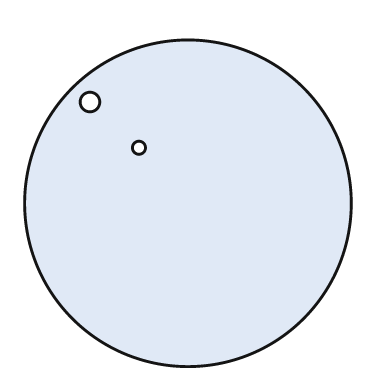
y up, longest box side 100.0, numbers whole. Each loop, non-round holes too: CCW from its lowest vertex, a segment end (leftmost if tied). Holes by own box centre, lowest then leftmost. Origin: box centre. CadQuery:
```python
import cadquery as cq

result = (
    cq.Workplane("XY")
    .moveTo(0.0, 0.0)
    .circle(50.0)
    .moveTo(-15.0, 17.0)
    .circle(2.0)
    .moveTo(-30.0, 31.0)
    .circle(3.0)
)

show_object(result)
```